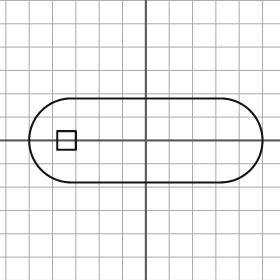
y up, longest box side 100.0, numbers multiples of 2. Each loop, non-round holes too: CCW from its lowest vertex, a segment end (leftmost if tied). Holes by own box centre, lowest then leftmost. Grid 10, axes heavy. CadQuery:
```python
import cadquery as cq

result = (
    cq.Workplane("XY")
    .moveTo(-32.0, -18.0)
    .lineTo(32.0, -18.0)
    .threePointArc((50.0, 0.0), (32.0, 18.0))
    .lineTo(-32.0, 18.0)
    .threePointArc((-50.0, 0.0), (-32.0, -18.0))
    .close()
    .moveTo(-38.0, -4.0)
    .lineTo(-30.0, -4.0)
    .lineTo(-30.0, 4.0)
    .lineTo(-38.0, 4.0)
    .close()
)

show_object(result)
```